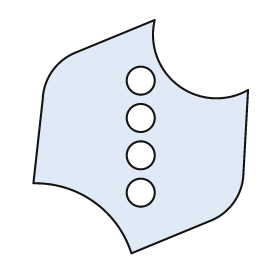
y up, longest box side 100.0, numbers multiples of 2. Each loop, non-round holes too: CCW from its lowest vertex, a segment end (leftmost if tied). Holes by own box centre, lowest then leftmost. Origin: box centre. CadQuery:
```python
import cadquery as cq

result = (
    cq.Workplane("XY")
    .moveTo(-4.0, -50.0)
    .lineTo(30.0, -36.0)
    .threePointArc((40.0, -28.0), (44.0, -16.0))
    .lineTo(46.0, 20.0)
    .threePointArc((16.0, 22.0), (6.0, 50.0))
    .lineTo(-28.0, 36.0)
    .threePointArc((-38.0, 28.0), (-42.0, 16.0))
    .lineTo(-46.0, -20.0)
    .threePointArc((-20.0, -28.0), (-4.0, -50.0))
    .close()
    .moveTo(0.0, -24.0)
    .circle(6.0)
    .moveTo(0.0, -8.0)
    .circle(6.0)
    .moveTo(0.0, 8.0)
    .circle(6.0)
    .moveTo(0.0, 24.0)
    .circle(6.0)
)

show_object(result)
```